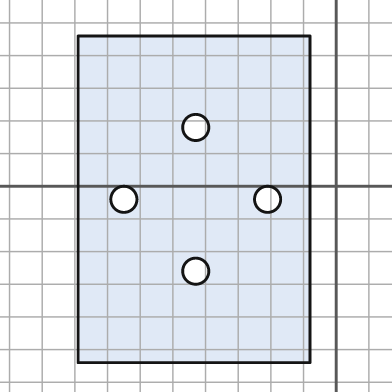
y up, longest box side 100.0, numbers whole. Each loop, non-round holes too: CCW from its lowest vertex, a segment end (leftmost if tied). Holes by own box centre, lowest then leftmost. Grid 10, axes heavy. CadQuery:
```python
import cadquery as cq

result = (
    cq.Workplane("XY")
    .moveTo(-79.0, -54.0)
    .lineTo(-8.0, -54.0)
    .lineTo(-8.0, 46.0)
    .lineTo(-79.0, 46.0)
    .close()
    .moveTo(-43.0, -26.0)
    .circle(4.0)
    .moveTo(-65.0, -4.0)
    .circle(4.0)
    .moveTo(-21.0, -4.0)
    .circle(4.0)
    .moveTo(-43.0, 18.0)
    .circle(4.0)
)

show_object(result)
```